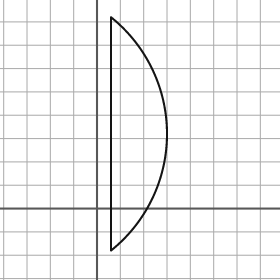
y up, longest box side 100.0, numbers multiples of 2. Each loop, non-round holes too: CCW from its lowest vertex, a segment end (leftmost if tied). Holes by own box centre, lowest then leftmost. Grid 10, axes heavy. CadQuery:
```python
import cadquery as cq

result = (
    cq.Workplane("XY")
    .moveTo(6.0, -18.0)
    .threePointArc((30.0, 32.0), (6.0, 82.0))
    .close()
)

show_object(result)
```